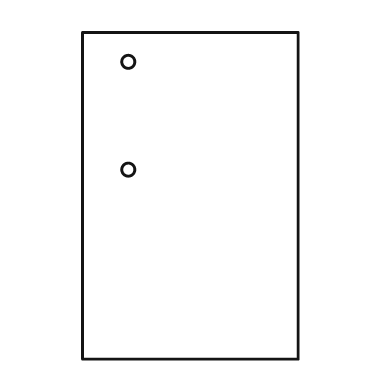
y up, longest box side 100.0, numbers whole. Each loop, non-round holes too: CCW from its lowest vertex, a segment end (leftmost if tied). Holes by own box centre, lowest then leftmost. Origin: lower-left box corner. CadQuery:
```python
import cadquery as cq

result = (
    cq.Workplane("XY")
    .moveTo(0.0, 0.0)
    .lineTo(66.0, 0.0)
    .lineTo(66.0, 100.0)
    .lineTo(0.0, 100.0)
    .close()
    .moveTo(14.0, 58.0)
    .circle(2.0)
    .moveTo(14.0, 91.0)
    .circle(2.0)
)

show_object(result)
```